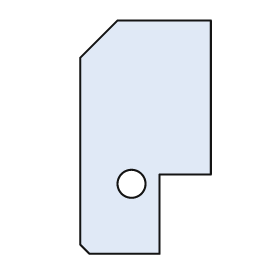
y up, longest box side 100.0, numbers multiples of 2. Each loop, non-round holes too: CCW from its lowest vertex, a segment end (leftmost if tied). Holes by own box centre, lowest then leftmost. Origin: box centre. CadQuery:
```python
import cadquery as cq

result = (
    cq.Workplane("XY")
    .moveTo(-24.0, -50.0)
    .lineTo(6.0, -50.0)
    .lineTo(6.0, -16.0)
    .lineTo(28.0, -16.0)
    .lineTo(28.0, 50.0)
    .lineTo(-12.0, 50.0)
    .lineTo(-28.0, 34.0)
    .lineTo(-28.0, -46.0)
    .close()
    .moveTo(-6.0, -20.0)
    .circle(6.0)
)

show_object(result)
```